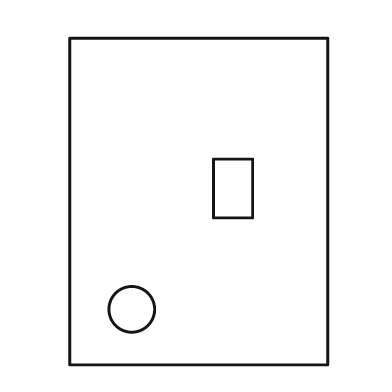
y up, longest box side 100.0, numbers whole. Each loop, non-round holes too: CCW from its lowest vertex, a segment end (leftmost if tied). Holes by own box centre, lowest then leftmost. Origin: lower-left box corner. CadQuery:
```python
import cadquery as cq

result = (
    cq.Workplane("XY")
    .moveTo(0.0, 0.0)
    .lineTo(79.0, 0.0)
    .lineTo(79.0, 100.0)
    .lineTo(0.0, 100.0)
    .close()
    .moveTo(19.0, 17.0)
    .circle(7.0)
    .moveTo(44.0, 45.0)
    .lineTo(56.0, 45.0)
    .lineTo(56.0, 63.0)
    .lineTo(44.0, 63.0)
    .close()
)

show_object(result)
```